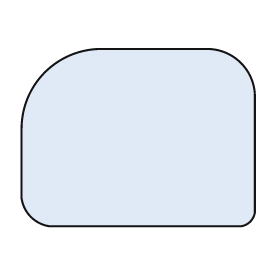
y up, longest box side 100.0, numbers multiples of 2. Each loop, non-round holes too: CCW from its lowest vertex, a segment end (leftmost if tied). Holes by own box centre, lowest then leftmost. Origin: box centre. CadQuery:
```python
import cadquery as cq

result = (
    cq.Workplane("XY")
    .moveTo(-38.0, -38.0)
    .lineTo(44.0, -38.0)
    .threePointArc((48.0, -36.0), (50.0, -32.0))
    .lineTo(50.0, 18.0)
    .threePointArc((44.0, 32.0), (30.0, 38.0))
    .lineTo(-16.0, 38.0)
    .threePointArc((-40.0, 28.0), (-50.0, 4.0))
    .lineTo(-50.0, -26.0)
    .threePointArc((-46.0, -34.0), (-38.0, -38.0))
    .close()
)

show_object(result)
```